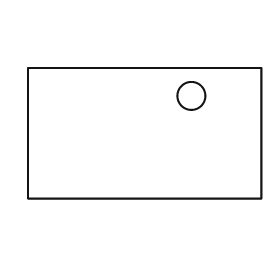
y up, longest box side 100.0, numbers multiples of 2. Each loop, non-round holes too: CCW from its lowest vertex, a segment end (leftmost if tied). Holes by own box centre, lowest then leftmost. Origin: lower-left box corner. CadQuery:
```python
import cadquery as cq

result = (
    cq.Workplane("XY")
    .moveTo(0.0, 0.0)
    .lineTo(100.0, 0.0)
    .lineTo(100.0, 56.0)
    .lineTo(0.0, 56.0)
    .close()
    .moveTo(70.0, 44.0)
    .circle(6.0)
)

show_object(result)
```